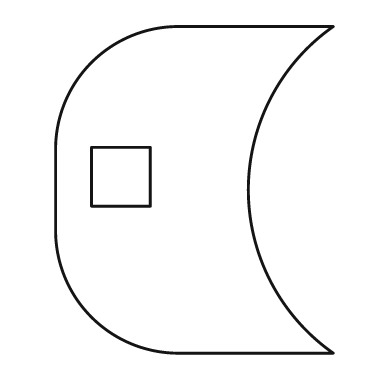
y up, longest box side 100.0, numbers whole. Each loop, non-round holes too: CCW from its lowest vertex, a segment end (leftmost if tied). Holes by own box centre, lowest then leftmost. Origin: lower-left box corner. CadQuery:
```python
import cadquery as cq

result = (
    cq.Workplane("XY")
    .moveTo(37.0, 0.0)
    .lineTo(85.0, 0.0)
    .threePointArc((59.0, 50.0), (85.0, 100.0))
    .lineTo(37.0, 100.0)
    .threePointArc((11.0, 89.0), (0.0, 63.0))
    .lineTo(0.0, 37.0)
    .threePointArc((11.0, 11.0), (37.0, 0.0))
    .close()
    .moveTo(11.0, 45.0)
    .lineTo(29.0, 45.0)
    .lineTo(29.0, 63.0)
    .lineTo(11.0, 63.0)
    .close()
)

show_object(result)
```